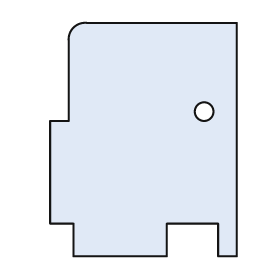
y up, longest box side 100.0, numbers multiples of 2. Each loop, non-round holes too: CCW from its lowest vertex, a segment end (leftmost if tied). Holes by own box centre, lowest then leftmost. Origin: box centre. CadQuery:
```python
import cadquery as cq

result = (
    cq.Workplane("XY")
    .moveTo(-30.0, -50.0)
    .lineTo(10.0, -50.0)
    .lineTo(10.0, -36.0)
    .lineTo(32.0, -36.0)
    .lineTo(32.0, -50.0)
    .lineTo(40.0, -50.0)
    .lineTo(40.0, 50.0)
    .lineTo(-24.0, 50.0)
    .threePointArc((-30.0, 48.0), (-32.0, 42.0))
    .lineTo(-32.0, 8.0)
    .lineTo(-40.0, 8.0)
    .lineTo(-40.0, -36.0)
    .lineTo(-30.0, -36.0)
    .close()
    .moveTo(26.0, 12.0)
    .circle(4.0)
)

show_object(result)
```